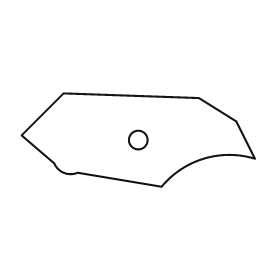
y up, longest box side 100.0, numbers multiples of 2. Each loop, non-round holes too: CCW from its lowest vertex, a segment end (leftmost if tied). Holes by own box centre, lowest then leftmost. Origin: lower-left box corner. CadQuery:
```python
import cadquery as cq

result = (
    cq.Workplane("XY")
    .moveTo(60.0, 0.0)
    .threePointArc((78.0, 12.0), (100.0, 12.0))
    .lineTo(92.0, 28.0)
    .lineTo(76.0, 38.0)
    .lineTo(18.0, 40.0)
    .lineTo(0.0, 22.0)
    .lineTo(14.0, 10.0)
    .threePointArc((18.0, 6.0), (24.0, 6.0))
    .close()
    .moveTo(50.0, 20.0)
    .circle(4.0)
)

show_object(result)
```